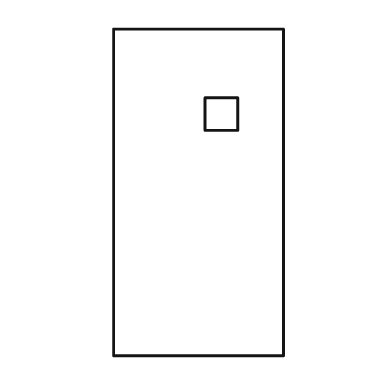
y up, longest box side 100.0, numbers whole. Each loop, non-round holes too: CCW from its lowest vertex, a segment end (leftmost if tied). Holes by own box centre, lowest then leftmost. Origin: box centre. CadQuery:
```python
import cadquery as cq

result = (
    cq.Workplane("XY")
    .moveTo(-26.0, -50.0)
    .lineTo(26.0, -50.0)
    .lineTo(26.0, 50.0)
    .lineTo(-26.0, 50.0)
    .close()
    .moveTo(2.0, 19.0)
    .lineTo(12.0, 19.0)
    .lineTo(12.0, 29.0)
    .lineTo(2.0, 29.0)
    .close()
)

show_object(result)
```